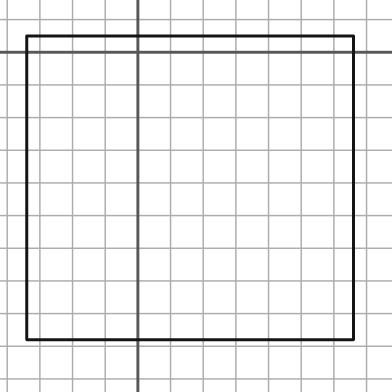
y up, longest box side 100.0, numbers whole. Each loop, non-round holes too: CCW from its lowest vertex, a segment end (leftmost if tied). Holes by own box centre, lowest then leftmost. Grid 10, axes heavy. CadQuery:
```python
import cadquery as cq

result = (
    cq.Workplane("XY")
    .moveTo(-34.0, -88.0)
    .lineTo(66.0, -88.0)
    .lineTo(66.0, 5.0)
    .lineTo(-34.0, 5.0)
    .close()
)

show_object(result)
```